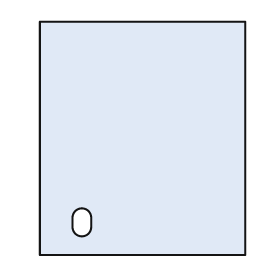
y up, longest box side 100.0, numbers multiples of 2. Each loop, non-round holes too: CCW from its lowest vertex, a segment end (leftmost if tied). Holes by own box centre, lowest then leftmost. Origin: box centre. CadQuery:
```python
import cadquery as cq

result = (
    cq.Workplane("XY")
    .moveTo(-44.0, -50.0)
    .lineTo(44.0, -50.0)
    .lineTo(44.0, 50.0)
    .lineTo(-44.0, 50.0)
    .close()
    .moveTo(-30.0, -38.0)
    .threePointArc((-26.0, -42.0), (-22.0, -38.0))
    .lineTo(-22.0, -34.0)
    .threePointArc((-26.0, -30.0), (-30.0, -34.0))
    .close()
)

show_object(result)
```